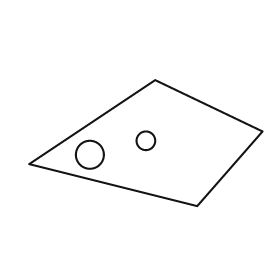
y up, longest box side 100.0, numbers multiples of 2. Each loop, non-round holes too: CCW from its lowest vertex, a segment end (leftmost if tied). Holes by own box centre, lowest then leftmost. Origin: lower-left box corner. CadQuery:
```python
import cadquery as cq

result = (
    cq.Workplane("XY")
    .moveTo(72.0, 0.0)
    .lineTo(100.0, 32.0)
    .lineTo(54.0, 54.0)
    .lineTo(0.0, 18.0)
    .close()
    .moveTo(26.0, 22.0)
    .circle(6.0)
    .moveTo(50.0, 28.0)
    .circle(4.0)
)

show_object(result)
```